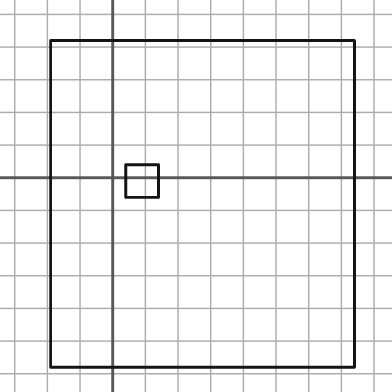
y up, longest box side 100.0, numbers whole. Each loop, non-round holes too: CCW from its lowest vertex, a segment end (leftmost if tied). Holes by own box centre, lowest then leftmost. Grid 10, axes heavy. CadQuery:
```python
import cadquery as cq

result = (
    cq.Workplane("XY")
    .moveTo(-19.0, -58.0)
    .lineTo(74.0, -58.0)
    .lineTo(74.0, 42.0)
    .lineTo(-19.0, 42.0)
    .close()
    .moveTo(4.0, -6.0)
    .lineTo(14.0, -6.0)
    .lineTo(14.0, 4.0)
    .lineTo(4.0, 4.0)
    .close()
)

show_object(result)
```